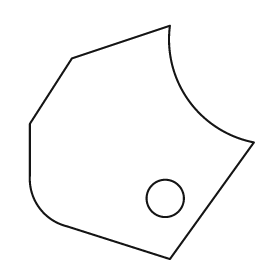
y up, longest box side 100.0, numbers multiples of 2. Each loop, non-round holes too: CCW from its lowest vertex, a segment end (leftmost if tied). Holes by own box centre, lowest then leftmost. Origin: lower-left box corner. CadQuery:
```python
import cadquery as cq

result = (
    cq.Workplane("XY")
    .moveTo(60.0, 0.0)
    .lineTo(96.0, 50.0)
    .threePointArc((68.0, 68.0), (60.0, 100.0))
    .lineTo(18.0, 86.0)
    .lineTo(0.0, 58.0)
    .lineTo(0.0, 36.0)
    .threePointArc((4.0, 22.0), (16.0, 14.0))
    .close()
    .moveTo(58.0, 26.0)
    .circle(8.0)
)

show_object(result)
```